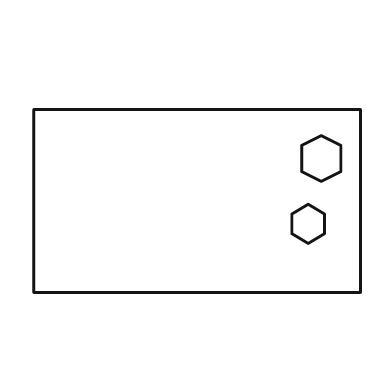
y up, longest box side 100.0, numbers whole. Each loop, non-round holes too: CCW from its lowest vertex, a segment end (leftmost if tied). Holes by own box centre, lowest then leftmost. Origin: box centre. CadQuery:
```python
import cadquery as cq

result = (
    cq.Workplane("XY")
    .moveTo(-50.0, -28.0)
    .lineTo(50.0, -28.0)
    .lineTo(50.0, 28.0)
    .lineTo(-50.0, 28.0)
    .close()
    .moveTo(34.0, -13.0)
    .lineTo(39.0, -10.0)
    .lineTo(39.0, -4.0)
    .lineTo(34.0, -1.0)
    .lineTo(29.0, -4.0)
    .lineTo(29.0, -10.0)
    .close()
    .moveTo(38.0, 6.0)
    .lineTo(44.0, 9.0)
    .lineTo(44.0, 17.0)
    .lineTo(38.0, 20.0)
    .lineTo(32.0, 17.0)
    .lineTo(32.0, 9.0)
    .close()
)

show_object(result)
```